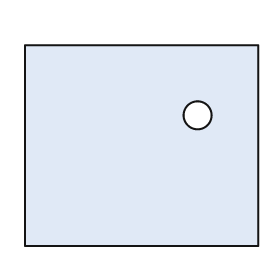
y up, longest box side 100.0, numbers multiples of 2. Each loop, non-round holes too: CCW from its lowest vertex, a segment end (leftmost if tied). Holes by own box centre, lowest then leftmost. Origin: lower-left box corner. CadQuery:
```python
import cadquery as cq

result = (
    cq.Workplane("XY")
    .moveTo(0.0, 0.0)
    .lineTo(100.0, 0.0)
    .lineTo(100.0, 86.0)
    .lineTo(0.0, 86.0)
    .close()
    .moveTo(74.0, 56.0)
    .circle(6.0)
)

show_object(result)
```